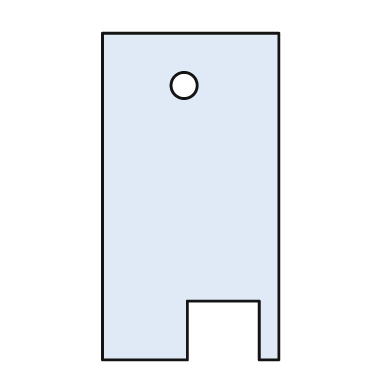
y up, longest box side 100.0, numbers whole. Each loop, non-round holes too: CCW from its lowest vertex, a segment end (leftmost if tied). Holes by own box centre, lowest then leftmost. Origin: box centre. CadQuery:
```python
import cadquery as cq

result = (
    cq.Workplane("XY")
    .moveTo(-27.0, -50.0)
    .lineTo(-1.0, -50.0)
    .lineTo(-1.0, -32.0)
    .lineTo(21.0, -32.0)
    .lineTo(21.0, -50.0)
    .lineTo(27.0, -50.0)
    .lineTo(27.0, 50.0)
    .lineTo(-27.0, 50.0)
    .close()
    .moveTo(-2.0, 34.0)
    .circle(4.0)
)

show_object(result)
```